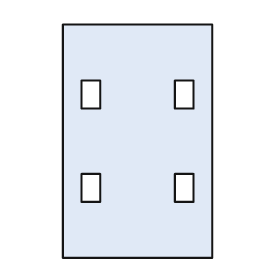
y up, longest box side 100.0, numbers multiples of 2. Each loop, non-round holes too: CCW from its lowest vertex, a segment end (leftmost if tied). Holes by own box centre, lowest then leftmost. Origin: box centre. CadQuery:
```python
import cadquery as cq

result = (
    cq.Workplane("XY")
    .moveTo(-32.0, -50.0)
    .lineTo(32.0, -50.0)
    .lineTo(32.0, 50.0)
    .lineTo(-32.0, 50.0)
    .close()
    .moveTo(-24.0, -26.0)
    .lineTo(-16.0, -26.0)
    .lineTo(-16.0, -14.0)
    .lineTo(-24.0, -14.0)
    .close()
    .moveTo(16.0, -26.0)
    .lineTo(24.0, -26.0)
    .lineTo(24.0, -14.0)
    .lineTo(16.0, -14.0)
    .close()
    .moveTo(-24.0, 14.0)
    .lineTo(-16.0, 14.0)
    .lineTo(-16.0, 26.0)
    .lineTo(-24.0, 26.0)
    .close()
    .moveTo(16.0, 14.0)
    .lineTo(24.0, 14.0)
    .lineTo(24.0, 26.0)
    .lineTo(16.0, 26.0)
    .close()
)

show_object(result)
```